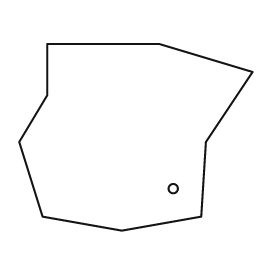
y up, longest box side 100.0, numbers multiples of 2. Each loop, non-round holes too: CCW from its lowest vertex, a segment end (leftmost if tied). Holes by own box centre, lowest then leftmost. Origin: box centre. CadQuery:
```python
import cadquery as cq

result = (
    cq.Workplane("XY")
    .moveTo(-6.0, -40.0)
    .lineTo(28.0, -34.0)
    .lineTo(30.0, -2.0)
    .lineTo(50.0, 28.0)
    .lineTo(10.0, 40.0)
    .lineTo(-38.0, 40.0)
    .lineTo(-38.0, 18.0)
    .lineTo(-50.0, -2.0)
    .lineTo(-40.0, -34.0)
    .close()
    .moveTo(16.0, -22.0)
    .circle(2.0)
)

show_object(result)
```